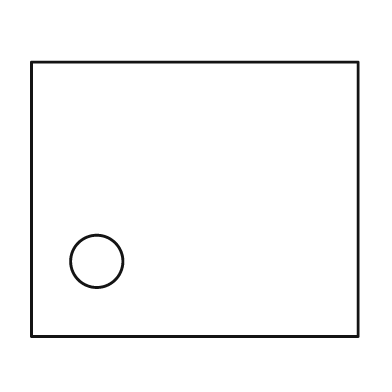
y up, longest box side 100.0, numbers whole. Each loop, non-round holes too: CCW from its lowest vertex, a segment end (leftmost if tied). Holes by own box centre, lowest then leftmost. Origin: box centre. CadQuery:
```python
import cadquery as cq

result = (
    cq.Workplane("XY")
    .moveTo(-50.0, -42.0)
    .lineTo(50.0, -42.0)
    .lineTo(50.0, 42.0)
    .lineTo(-50.0, 42.0)
    .close()
    .moveTo(-30.0, -19.0)
    .circle(8.0)
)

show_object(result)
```